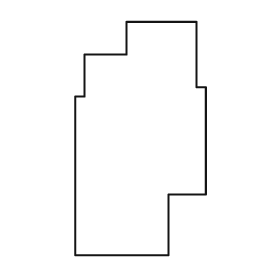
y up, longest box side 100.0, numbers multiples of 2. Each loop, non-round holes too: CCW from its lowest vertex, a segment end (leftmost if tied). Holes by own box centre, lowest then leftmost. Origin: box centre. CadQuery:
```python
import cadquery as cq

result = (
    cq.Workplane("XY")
    .moveTo(-28.0, -50.0)
    .lineTo(12.0, -50.0)
    .lineTo(12.0, -24.0)
    .lineTo(28.0, -24.0)
    .lineTo(28.0, 22.0)
    .lineTo(24.0, 22.0)
    .lineTo(24.0, 50.0)
    .lineTo(-6.0, 50.0)
    .lineTo(-6.0, 36.0)
    .lineTo(-24.0, 36.0)
    .lineTo(-24.0, 18.0)
    .lineTo(-28.0, 18.0)
    .close()
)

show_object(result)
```